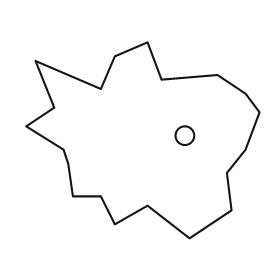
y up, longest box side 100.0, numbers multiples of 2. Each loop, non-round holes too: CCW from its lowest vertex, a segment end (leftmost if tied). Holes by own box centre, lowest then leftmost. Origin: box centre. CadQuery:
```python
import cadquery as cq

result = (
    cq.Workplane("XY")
    .moveTo(20.0, -42.0)
    .lineTo(38.0, -30.0)
    .lineTo(36.0, -14.0)
    .lineTo(44.0, -4.0)
    .lineTo(50.0, 12.0)
    .lineTo(44.0, 20.0)
    .lineTo(32.0, 28.0)
    .lineTo(8.0, 26.0)
    .lineTo(2.0, 42.0)
    .lineTo(-12.0, 36.0)
    .lineTo(-18.0, 22.0)
    .lineTo(-46.0, 34.0)
    .lineTo(-38.0, 14.0)
    .lineTo(-50.0, 6.0)
    .lineTo(-34.0, -4.0)
    .lineTo(-32.0, -10.0)
    .lineTo(-30.0, -24.0)
    .lineTo(-18.0, -24.0)
    .lineTo(-12.0, -36.0)
    .lineTo(2.0, -28.0)
    .close()
    .moveTo(18.0, 2.0)
    .circle(4.0)
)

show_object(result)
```